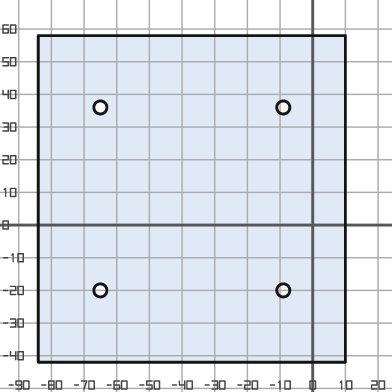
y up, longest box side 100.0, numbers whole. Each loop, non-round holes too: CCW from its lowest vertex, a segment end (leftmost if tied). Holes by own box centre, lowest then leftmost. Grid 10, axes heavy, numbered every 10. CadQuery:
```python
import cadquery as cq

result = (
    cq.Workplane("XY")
    .moveTo(-84.0, -42.0)
    .lineTo(10.0, -42.0)
    .lineTo(10.0, 58.0)
    .lineTo(-84.0, 58.0)
    .close()
    .moveTo(-65.0, -20.0)
    .circle(2.0)
    .moveTo(-9.0, -20.0)
    .circle(2.0)
    .moveTo(-65.0, 36.0)
    .circle(2.0)
    .moveTo(-9.0, 36.0)
    .circle(2.0)
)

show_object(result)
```